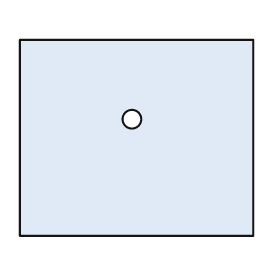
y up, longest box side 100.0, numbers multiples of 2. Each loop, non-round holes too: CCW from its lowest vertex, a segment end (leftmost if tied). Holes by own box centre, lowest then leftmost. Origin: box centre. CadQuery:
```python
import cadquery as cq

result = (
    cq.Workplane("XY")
    .moveTo(-50.0, -42.0)
    .lineTo(50.0, -42.0)
    .lineTo(50.0, 42.0)
    .lineTo(-50.0, 42.0)
    .close()
    .moveTo(-2.0, 8.0)
    .circle(4.0)
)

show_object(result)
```